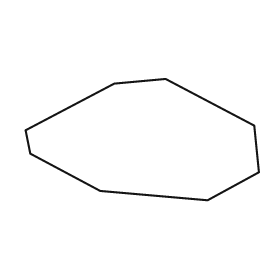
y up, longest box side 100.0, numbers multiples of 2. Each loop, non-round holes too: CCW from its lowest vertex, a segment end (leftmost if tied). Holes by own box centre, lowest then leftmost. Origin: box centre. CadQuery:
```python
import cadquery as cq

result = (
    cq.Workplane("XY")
    .moveTo(28.0, -26.0)
    .lineTo(50.0, -14.0)
    .lineTo(48.0, 6.0)
    .lineTo(10.0, 26.0)
    .lineTo(-12.0, 24.0)
    .lineTo(-50.0, 4.0)
    .lineTo(-48.0, -6.0)
    .lineTo(-18.0, -22.0)
    .close()
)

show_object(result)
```